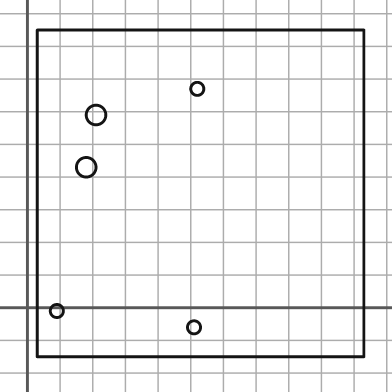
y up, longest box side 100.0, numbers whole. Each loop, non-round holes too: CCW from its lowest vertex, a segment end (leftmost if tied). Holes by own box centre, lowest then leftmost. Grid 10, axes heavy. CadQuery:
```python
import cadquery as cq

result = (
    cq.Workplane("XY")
    .moveTo(3.0, -15.0)
    .lineTo(103.0, -15.0)
    .lineTo(103.0, 85.0)
    .lineTo(3.0, 85.0)
    .close()
    .moveTo(51.0, -6.0)
    .circle(2.0)
    .moveTo(9.0, -1.0)
    .circle(2.0)
    .moveTo(18.0, 43.0)
    .circle(3.0)
    .moveTo(21.0, 59.0)
    .circle(3.0)
    .moveTo(52.0, 67.0)
    .circle(2.0)
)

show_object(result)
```